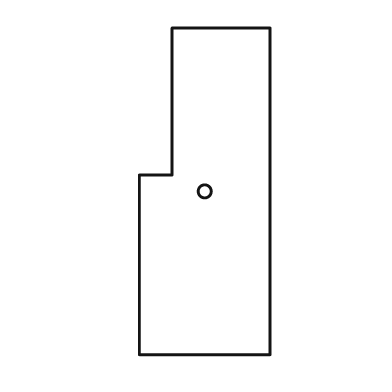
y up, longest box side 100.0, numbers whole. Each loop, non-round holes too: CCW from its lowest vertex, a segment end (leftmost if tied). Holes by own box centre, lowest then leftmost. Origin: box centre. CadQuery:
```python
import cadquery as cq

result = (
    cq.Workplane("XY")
    .moveTo(-20.0, -50.0)
    .lineTo(20.0, -50.0)
    .lineTo(20.0, 50.0)
    .lineTo(-10.0, 50.0)
    .lineTo(-10.0, 5.0)
    .lineTo(-20.0, 5.0)
    .close()
    .moveTo(0.0, 0.0)
    .circle(2.0)
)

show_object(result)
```